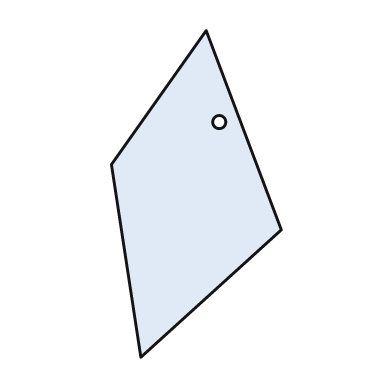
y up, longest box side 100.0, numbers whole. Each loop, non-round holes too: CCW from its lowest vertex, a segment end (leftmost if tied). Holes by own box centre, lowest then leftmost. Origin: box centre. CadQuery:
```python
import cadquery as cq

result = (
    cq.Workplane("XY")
    .moveTo(-17.0, -50.0)
    .lineTo(26.0, -11.0)
    .lineTo(3.0, 50.0)
    .lineTo(-26.0, 9.0)
    .close()
    .moveTo(7.0, 22.0)
    .circle(2.0)
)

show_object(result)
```